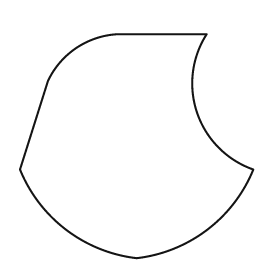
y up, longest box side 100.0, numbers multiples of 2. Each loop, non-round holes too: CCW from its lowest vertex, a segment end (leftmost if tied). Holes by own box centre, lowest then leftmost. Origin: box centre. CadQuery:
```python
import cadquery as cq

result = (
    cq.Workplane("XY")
    .moveTo(0.0, -48.0)
    .threePointArc((30.0, -36.0), (50.0, -10.0))
    .threePointArc((26.0, 14.0), (30.0, 48.0))
    .lineTo(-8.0, 48.0)
    .threePointArc((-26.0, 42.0), (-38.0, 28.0))
    .lineTo(-50.0, -10.0)
    .threePointArc((-30.0, -36.0), (0.0, -48.0))
    .close()
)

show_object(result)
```